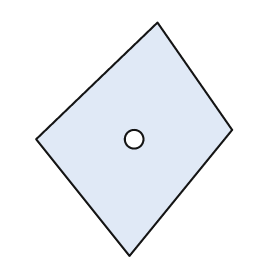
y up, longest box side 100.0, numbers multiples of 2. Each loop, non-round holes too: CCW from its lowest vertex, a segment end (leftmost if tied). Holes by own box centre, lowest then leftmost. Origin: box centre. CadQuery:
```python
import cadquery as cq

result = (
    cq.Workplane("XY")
    .moveTo(-2.0, -50.0)
    .lineTo(42.0, 4.0)
    .lineTo(10.0, 50.0)
    .lineTo(-42.0, 0.0)
    .close()
    .moveTo(0.0, 0.0)
    .circle(4.0)
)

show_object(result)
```